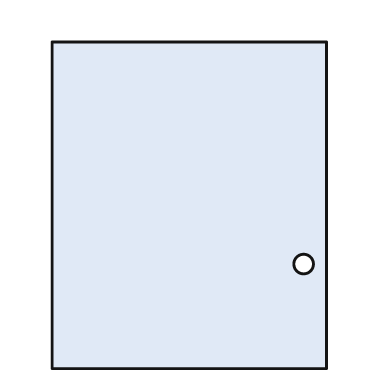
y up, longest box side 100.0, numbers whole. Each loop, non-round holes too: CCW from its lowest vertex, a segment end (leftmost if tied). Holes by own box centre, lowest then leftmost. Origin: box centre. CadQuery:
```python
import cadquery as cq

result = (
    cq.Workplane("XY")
    .moveTo(-42.0, -50.0)
    .lineTo(42.0, -50.0)
    .lineTo(42.0, 50.0)
    .lineTo(-42.0, 50.0)
    .close()
    .moveTo(35.0, -18.0)
    .circle(3.0)
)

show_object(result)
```